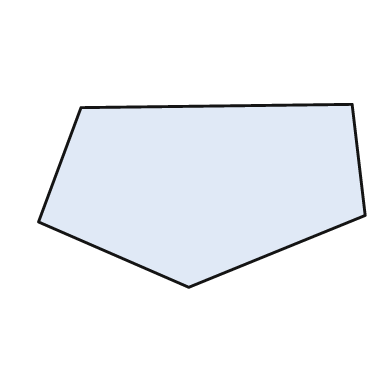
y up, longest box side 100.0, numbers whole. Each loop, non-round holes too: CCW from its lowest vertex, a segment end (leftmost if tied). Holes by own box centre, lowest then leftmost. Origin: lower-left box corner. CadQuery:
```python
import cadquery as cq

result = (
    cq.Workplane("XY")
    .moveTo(46.0, 0.0)
    .lineTo(100.0, 22.0)
    .lineTo(96.0, 56.0)
    .lineTo(13.0, 55.0)
    .lineTo(0.0, 20.0)
    .close()
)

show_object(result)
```